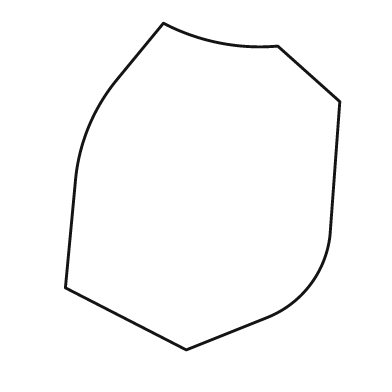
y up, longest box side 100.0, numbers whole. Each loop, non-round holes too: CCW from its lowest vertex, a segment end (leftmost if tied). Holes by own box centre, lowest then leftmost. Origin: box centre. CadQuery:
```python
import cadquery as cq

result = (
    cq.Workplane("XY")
    .moveTo(-5.0, -50.0)
    .lineTo(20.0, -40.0)
    .threePointArc((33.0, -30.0), (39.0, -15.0))
    .lineTo(42.0, 26.0)
    .lineTo(23.0, 43.0)
    .threePointArc((5.0, 44.0), (-12.0, 50.0))
    .lineTo(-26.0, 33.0)
    .threePointArc((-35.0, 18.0), (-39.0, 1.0))
    .lineTo(-42.0, -31.0)
    .close()
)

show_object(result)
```